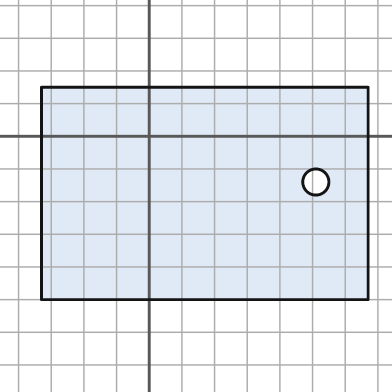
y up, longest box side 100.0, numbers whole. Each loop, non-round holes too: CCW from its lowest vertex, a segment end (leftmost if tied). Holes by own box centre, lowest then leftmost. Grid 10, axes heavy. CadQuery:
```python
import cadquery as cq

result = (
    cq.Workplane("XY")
    .moveTo(-33.0, -50.0)
    .lineTo(67.0, -50.0)
    .lineTo(67.0, 15.0)
    .lineTo(-33.0, 15.0)
    .close()
    .moveTo(51.0, -14.0)
    .circle(4.0)
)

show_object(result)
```